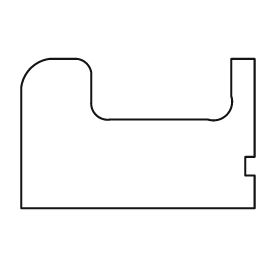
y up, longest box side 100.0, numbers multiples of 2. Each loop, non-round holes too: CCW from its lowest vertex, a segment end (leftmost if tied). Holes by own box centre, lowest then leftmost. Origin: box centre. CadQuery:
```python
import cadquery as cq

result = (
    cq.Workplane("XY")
    .moveTo(-50.0, -32.0)
    .lineTo(50.0, -32.0)
    .lineTo(50.0, -18.0)
    .lineTo(46.0, -18.0)
    .lineTo(46.0, -10.0)
    .lineTo(50.0, -10.0)
    .lineTo(50.0, 32.0)
    .lineTo(40.0, 32.0)
    .lineTo(40.0, 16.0)
    .threePointArc((38.0, 8.0), (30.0, 6.0))
    .lineTo(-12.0, 6.0)
    .threePointArc((-18.0, 8.0), (-20.0, 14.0))
    .lineTo(-20.0, 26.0)
    .threePointArc((-22.0, 30.0), (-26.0, 32.0))
    .lineTo(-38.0, 32.0)
    .threePointArc((-46.0, 28.0), (-50.0, 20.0))
    .close()
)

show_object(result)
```